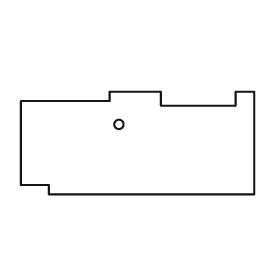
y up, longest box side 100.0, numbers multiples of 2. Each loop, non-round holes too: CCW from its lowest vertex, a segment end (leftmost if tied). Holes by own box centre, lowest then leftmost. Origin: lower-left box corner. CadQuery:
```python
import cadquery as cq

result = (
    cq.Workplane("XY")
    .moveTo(12.0, 0.0)
    .lineTo(100.0, 0.0)
    .lineTo(100.0, 44.0)
    .lineTo(92.0, 44.0)
    .lineTo(92.0, 38.0)
    .lineTo(60.0, 38.0)
    .lineTo(60.0, 44.0)
    .lineTo(38.0, 44.0)
    .lineTo(38.0, 40.0)
    .lineTo(0.0, 40.0)
    .lineTo(0.0, 4.0)
    .lineTo(12.0, 4.0)
    .close()
    .moveTo(42.0, 30.0)
    .circle(2.0)
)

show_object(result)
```